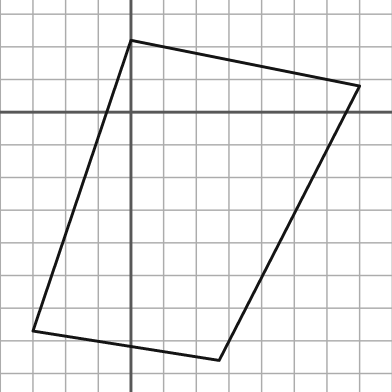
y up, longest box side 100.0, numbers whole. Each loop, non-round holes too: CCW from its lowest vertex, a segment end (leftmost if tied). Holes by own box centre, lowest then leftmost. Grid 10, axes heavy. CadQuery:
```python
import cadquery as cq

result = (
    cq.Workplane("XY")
    .moveTo(27.0, -76.0)
    .lineTo(70.0, 8.0)
    .lineTo(0.0, 22.0)
    .lineTo(-30.0, -67.0)
    .close()
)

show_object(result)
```